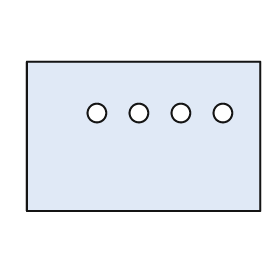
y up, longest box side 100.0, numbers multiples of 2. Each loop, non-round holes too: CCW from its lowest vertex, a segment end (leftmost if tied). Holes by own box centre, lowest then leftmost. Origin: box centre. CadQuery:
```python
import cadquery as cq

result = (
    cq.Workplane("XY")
    .moveTo(-50.0, -32.0)
    .lineTo(50.0, -32.0)
    .lineTo(50.0, 32.0)
    .lineTo(-50.0, 32.0)
    .close()
    .moveTo(-20.0, 10.0)
    .circle(4.0)
    .moveTo(-2.0, 10.0)
    .circle(4.0)
    .moveTo(16.0, 10.0)
    .circle(4.0)
    .moveTo(34.0, 10.0)
    .circle(4.0)
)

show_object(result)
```